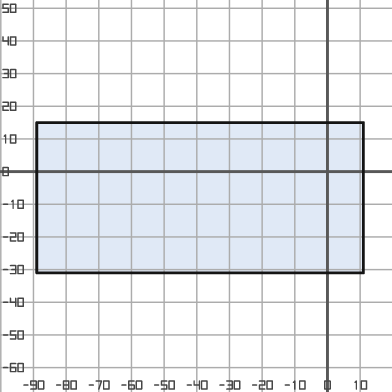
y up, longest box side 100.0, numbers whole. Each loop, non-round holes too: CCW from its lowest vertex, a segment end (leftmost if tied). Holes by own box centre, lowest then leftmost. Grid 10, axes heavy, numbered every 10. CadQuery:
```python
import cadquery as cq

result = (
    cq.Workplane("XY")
    .moveTo(-89.0, -31.0)
    .lineTo(11.0, -31.0)
    .lineTo(11.0, 15.0)
    .lineTo(-89.0, 15.0)
    .close()
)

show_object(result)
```